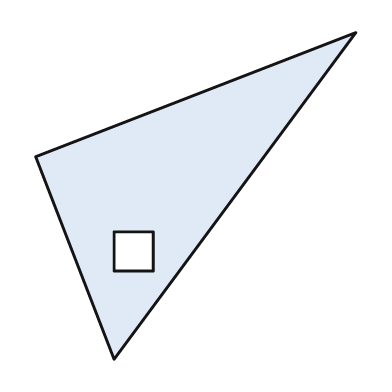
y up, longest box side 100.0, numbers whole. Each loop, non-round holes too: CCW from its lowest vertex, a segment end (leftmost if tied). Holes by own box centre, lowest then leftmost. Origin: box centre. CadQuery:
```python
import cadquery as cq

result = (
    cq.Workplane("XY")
    .moveTo(-25.0, -50.0)
    .lineTo(49.0, 50.0)
    .lineTo(-49.0, 12.0)
    .close()
    .moveTo(-25.0, -23.0)
    .lineTo(-13.0, -23.0)
    .lineTo(-13.0, -11.0)
    .lineTo(-25.0, -11.0)
    .close()
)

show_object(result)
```